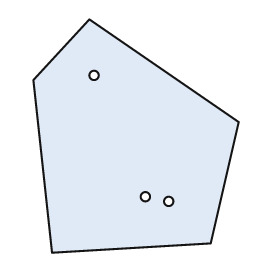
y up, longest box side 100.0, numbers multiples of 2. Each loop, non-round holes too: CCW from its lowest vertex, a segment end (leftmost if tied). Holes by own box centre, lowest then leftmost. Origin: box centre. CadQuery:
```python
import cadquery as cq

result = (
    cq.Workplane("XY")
    .moveTo(-36.0, -50.0)
    .lineTo(32.0, -46.0)
    .lineTo(44.0, 6.0)
    .lineTo(-20.0, 50.0)
    .lineTo(-44.0, 24.0)
    .close()
    .moveTo(14.0, -28.0)
    .circle(2.0)
    .moveTo(4.0, -26.0)
    .circle(2.0)
    .moveTo(-18.0, 26.0)
    .circle(2.0)
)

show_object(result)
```